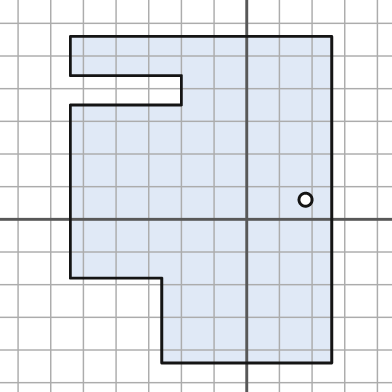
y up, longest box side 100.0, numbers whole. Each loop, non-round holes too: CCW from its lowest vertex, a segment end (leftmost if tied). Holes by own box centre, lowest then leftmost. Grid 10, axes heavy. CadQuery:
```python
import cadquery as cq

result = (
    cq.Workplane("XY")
    .moveTo(-26.0, -44.0)
    .lineTo(26.0, -44.0)
    .lineTo(26.0, 56.0)
    .lineTo(-54.0, 56.0)
    .lineTo(-54.0, 44.0)
    .lineTo(-20.0, 44.0)
    .lineTo(-20.0, 35.0)
    .lineTo(-54.0, 35.0)
    .lineTo(-54.0, -18.0)
    .lineTo(-26.0, -18.0)
    .close()
    .moveTo(18.0, 6.0)
    .circle(2.0)
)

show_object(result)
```